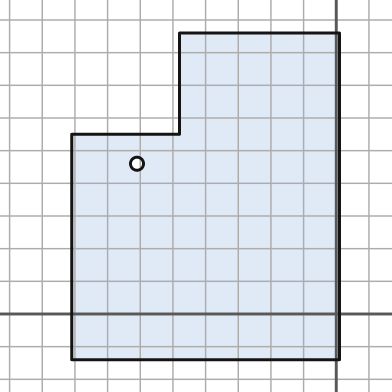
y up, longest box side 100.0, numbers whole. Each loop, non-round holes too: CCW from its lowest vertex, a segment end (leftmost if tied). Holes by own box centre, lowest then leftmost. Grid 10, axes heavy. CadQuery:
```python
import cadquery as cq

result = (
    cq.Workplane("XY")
    .moveTo(-81.0, -14.0)
    .lineTo(1.0, -14.0)
    .lineTo(1.0, 86.0)
    .lineTo(-48.0, 86.0)
    .lineTo(-48.0, 55.0)
    .lineTo(-81.0, 55.0)
    .close()
    .moveTo(-61.0, 46.0)
    .circle(2.0)
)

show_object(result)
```